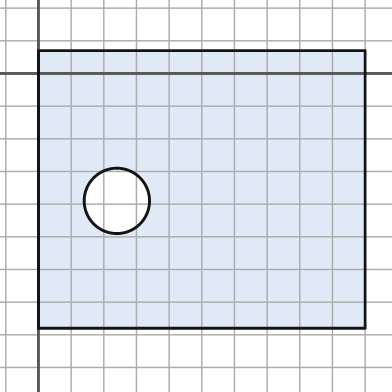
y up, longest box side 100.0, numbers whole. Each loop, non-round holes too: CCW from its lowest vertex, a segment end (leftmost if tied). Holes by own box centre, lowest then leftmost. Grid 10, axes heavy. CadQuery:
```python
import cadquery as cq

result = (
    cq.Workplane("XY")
    .moveTo(0.0, -78.0)
    .lineTo(100.0, -78.0)
    .lineTo(100.0, 7.0)
    .lineTo(0.0, 7.0)
    .close()
    .moveTo(24.0, -39.0)
    .circle(10.0)
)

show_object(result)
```